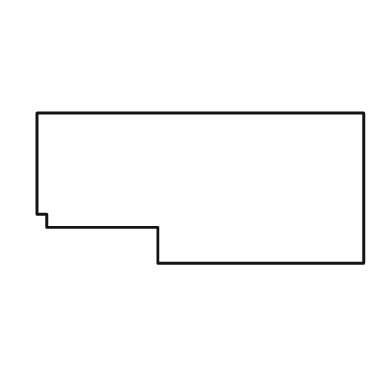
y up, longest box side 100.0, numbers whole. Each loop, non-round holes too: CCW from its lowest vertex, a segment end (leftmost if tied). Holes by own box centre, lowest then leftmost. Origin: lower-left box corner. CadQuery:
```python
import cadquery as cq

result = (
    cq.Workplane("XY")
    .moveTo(37.0, 0.0)
    .lineTo(100.0, 0.0)
    .lineTo(100.0, 46.0)
    .lineTo(0.0, 46.0)
    .lineTo(0.0, 15.0)
    .lineTo(3.0, 15.0)
    .lineTo(3.0, 11.0)
    .lineTo(37.0, 11.0)
    .close()
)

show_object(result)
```